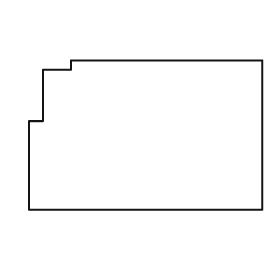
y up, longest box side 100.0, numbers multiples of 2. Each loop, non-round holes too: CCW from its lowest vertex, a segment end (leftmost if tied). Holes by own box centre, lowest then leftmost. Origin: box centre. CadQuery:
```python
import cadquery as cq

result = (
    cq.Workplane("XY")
    .moveTo(-50.0, -32.0)
    .lineTo(50.0, -32.0)
    .lineTo(50.0, 32.0)
    .lineTo(-32.0, 32.0)
    .lineTo(-32.0, 28.0)
    .lineTo(-44.0, 28.0)
    .lineTo(-44.0, 6.0)
    .lineTo(-50.0, 6.0)
    .close()
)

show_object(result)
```